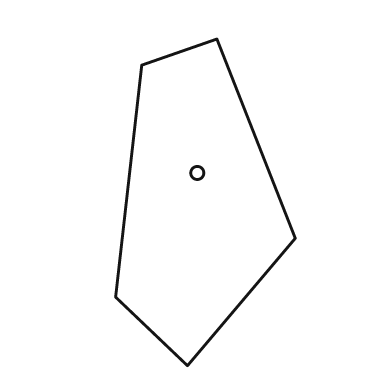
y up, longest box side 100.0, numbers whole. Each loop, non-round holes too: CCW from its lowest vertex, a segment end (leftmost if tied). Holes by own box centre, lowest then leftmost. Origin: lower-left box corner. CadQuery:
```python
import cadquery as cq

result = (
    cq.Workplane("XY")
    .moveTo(22.0, 0.0)
    .lineTo(55.0, 39.0)
    .lineTo(31.0, 100.0)
    .lineTo(8.0, 92.0)
    .lineTo(0.0, 21.0)
    .close()
    .moveTo(25.0, 59.0)
    .circle(2.0)
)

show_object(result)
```